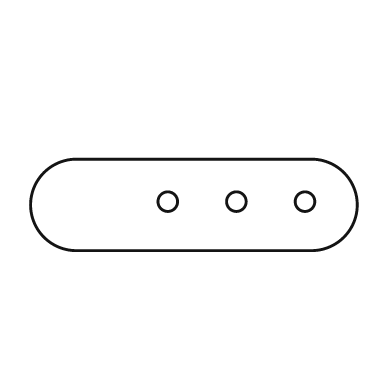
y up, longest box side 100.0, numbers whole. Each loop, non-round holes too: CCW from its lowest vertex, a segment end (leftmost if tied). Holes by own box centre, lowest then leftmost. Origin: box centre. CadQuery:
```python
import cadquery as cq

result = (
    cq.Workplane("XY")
    .moveTo(-36.0, -14.0)
    .lineTo(36.0, -14.0)
    .threePointArc((50.0, 0.0), (36.0, 14.0))
    .lineTo(-36.0, 14.0)
    .threePointArc((-50.0, 0.0), (-36.0, -14.0))
    .close()
    .moveTo(-8.0, 1.0)
    .circle(3.0)
    .moveTo(13.0, 1.0)
    .circle(3.0)
    .moveTo(34.0, 1.0)
    .circle(3.0)
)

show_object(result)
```